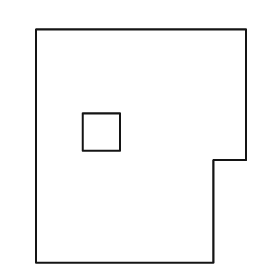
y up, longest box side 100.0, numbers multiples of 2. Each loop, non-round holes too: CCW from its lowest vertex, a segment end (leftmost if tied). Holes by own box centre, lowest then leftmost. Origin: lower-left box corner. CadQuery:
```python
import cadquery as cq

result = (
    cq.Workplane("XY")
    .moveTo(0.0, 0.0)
    .lineTo(76.0, 0.0)
    .lineTo(76.0, 44.0)
    .lineTo(90.0, 44.0)
    .lineTo(90.0, 100.0)
    .lineTo(0.0, 100.0)
    .close()
    .moveTo(20.0, 48.0)
    .lineTo(36.0, 48.0)
    .lineTo(36.0, 64.0)
    .lineTo(20.0, 64.0)
    .close()
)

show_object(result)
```